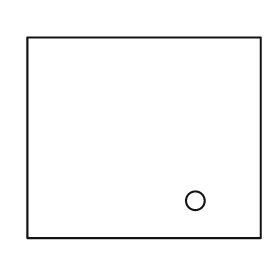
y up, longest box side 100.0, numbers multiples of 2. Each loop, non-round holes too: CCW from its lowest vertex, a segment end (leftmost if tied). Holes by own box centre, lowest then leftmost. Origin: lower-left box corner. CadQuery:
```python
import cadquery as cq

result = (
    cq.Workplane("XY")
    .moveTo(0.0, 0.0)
    .lineTo(100.0, 0.0)
    .lineTo(100.0, 86.0)
    .lineTo(0.0, 86.0)
    .close()
    .moveTo(72.0, 16.0)
    .circle(4.0)
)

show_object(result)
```